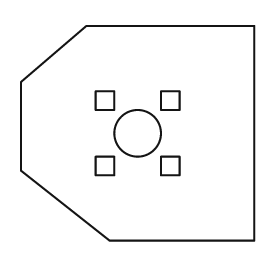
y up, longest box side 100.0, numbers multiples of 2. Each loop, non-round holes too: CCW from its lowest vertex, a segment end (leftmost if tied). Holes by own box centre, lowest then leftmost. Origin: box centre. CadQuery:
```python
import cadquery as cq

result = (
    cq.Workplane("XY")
    .moveTo(-12.0, -46.0)
    .lineTo(50.0, -46.0)
    .lineTo(50.0, 46.0)
    .lineTo(-22.0, 46.0)
    .lineTo(-50.0, 22.0)
    .lineTo(-50.0, -16.0)
    .close()
    .moveTo(-18.0, -18.0)
    .lineTo(-10.0, -18.0)
    .lineTo(-10.0, -10.0)
    .lineTo(-18.0, -10.0)
    .close()
    .moveTo(10.0, -18.0)
    .lineTo(18.0, -18.0)
    .lineTo(18.0, -10.0)
    .lineTo(10.0, -10.0)
    .close()
    .moveTo(0.0, 0.0)
    .circle(10.0)
    .moveTo(-18.0, 10.0)
    .lineTo(-10.0, 10.0)
    .lineTo(-10.0, 18.0)
    .lineTo(-18.0, 18.0)
    .close()
    .moveTo(10.0, 10.0)
    .lineTo(18.0, 10.0)
    .lineTo(18.0, 18.0)
    .lineTo(10.0, 18.0)
    .close()
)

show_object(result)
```